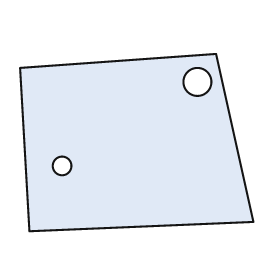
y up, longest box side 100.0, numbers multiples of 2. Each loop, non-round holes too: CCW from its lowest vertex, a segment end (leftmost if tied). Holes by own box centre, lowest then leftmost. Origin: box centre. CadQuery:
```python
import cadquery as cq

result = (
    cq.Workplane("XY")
    .moveTo(-46.0, -38.0)
    .lineTo(50.0, -34.0)
    .lineTo(34.0, 38.0)
    .lineTo(-50.0, 32.0)
    .close()
    .moveTo(-32.0, -10.0)
    .circle(4.0)
    .moveTo(26.0, 26.0)
    .circle(6.0)
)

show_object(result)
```